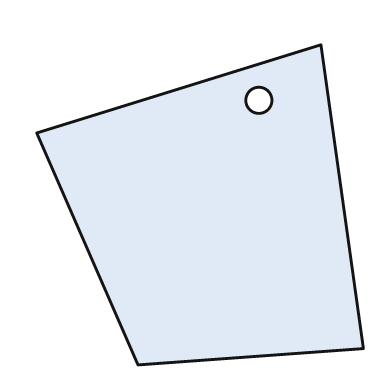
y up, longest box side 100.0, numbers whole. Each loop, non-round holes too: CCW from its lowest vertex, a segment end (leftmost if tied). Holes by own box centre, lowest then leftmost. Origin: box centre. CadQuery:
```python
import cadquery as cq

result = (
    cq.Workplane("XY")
    .moveTo(-19.0, -49.0)
    .lineTo(50.0, -44.0)
    .lineTo(37.0, 49.0)
    .lineTo(-50.0, 22.0)
    .close()
    .moveTo(18.0, 32.0)
    .circle(4.0)
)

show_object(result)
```